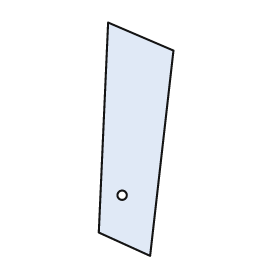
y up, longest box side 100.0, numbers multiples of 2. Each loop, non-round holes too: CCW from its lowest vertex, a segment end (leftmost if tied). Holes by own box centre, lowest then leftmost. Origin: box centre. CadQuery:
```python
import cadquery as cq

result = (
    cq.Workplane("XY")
    .moveTo(6.0, -50.0)
    .lineTo(16.0, 38.0)
    .lineTo(-12.0, 50.0)
    .lineTo(-16.0, -40.0)
    .close()
    .moveTo(-6.0, -24.0)
    .circle(2.0)
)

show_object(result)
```